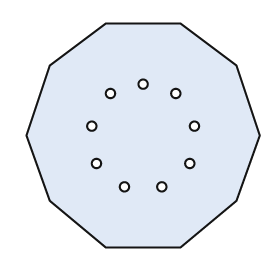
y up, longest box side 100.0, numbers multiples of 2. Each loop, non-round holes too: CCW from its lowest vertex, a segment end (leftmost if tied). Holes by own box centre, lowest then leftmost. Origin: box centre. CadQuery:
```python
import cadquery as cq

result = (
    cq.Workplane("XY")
    .moveTo(-16.0, -48.0)
    .lineTo(16.0, -48.0)
    .lineTo(40.0, -28.0)
    .lineTo(50.0, 0.0)
    .lineTo(40.0, 30.0)
    .lineTo(16.0, 48.0)
    .lineTo(-16.0, 48.0)
    .lineTo(-40.0, 30.0)
    .lineTo(-50.0, 0.0)
    .lineTo(-40.0, -28.0)
    .close()
    .moveTo(-8.0, -22.0)
    .circle(2.0)
    .moveTo(8.0, -22.0)
    .circle(2.0)
    .moveTo(-20.0, -12.0)
    .circle(2.0)
    .moveTo(20.0, -12.0)
    .circle(2.0)
    .moveTo(-22.0, 4.0)
    .circle(2.0)
    .moveTo(22.0, 4.0)
    .circle(2.0)
    .moveTo(-14.0, 18.0)
    .circle(2.0)
    .moveTo(14.0, 18.0)
    .circle(2.0)
    .moveTo(0.0, 22.0)
    .circle(2.0)
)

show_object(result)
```